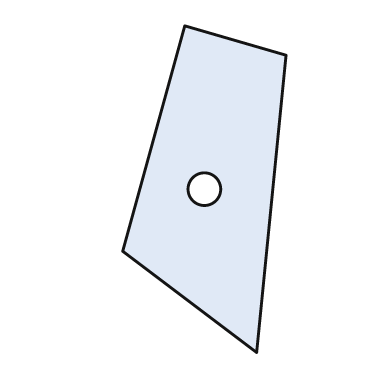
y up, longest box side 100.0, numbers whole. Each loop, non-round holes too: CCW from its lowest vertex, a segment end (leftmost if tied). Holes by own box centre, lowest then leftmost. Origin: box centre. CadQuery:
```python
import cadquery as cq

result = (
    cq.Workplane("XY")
    .moveTo(16.0, -50.0)
    .lineTo(25.0, 41.0)
    .lineTo(-6.0, 50.0)
    .lineTo(-25.0, -19.0)
    .close()
    .moveTo(0.0, 0.0)
    .circle(5.0)
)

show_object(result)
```